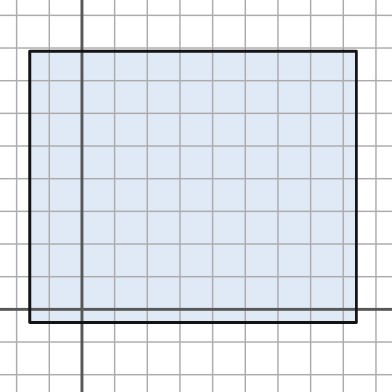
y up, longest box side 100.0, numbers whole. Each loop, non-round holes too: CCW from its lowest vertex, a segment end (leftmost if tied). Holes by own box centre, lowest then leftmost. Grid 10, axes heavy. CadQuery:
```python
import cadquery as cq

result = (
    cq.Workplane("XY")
    .moveTo(-16.0, -4.0)
    .lineTo(84.0, -4.0)
    .lineTo(84.0, 79.0)
    .lineTo(-16.0, 79.0)
    .close()
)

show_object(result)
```